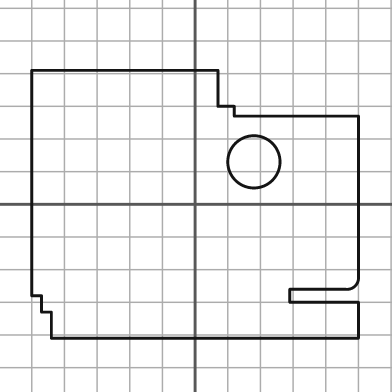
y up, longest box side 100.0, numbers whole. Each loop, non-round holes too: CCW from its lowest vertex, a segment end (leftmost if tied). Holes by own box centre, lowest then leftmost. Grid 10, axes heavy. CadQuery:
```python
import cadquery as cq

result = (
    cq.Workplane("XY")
    .moveTo(-44.0, -41.0)
    .lineTo(50.0, -41.0)
    .lineTo(50.0, -30.0)
    .lineTo(29.0, -30.0)
    .lineTo(29.0, -26.0)
    .lineTo(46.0, -26.0)
    .threePointArc((49.0, -25.0), (50.0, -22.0))
    .lineTo(50.0, 27.0)
    .lineTo(12.0, 27.0)
    .lineTo(12.0, 30.0)
    .lineTo(7.0, 30.0)
    .lineTo(7.0, 41.0)
    .lineTo(-50.0, 41.0)
    .lineTo(-50.0, -28.0)
    .lineTo(-47.0, -28.0)
    .lineTo(-47.0, -33.0)
    .lineTo(-44.0, -33.0)
    .close()
    .moveTo(18.0, 13.0)
    .circle(8.0)
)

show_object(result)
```